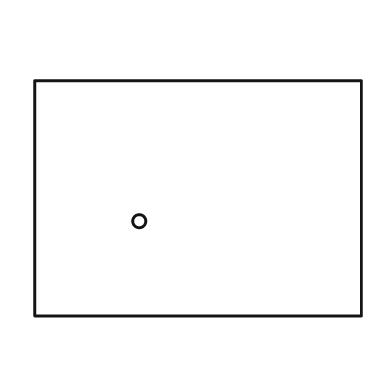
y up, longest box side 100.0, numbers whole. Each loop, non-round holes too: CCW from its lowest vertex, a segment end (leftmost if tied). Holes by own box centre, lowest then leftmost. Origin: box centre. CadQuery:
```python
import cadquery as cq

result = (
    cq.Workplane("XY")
    .moveTo(-50.0, -36.0)
    .lineTo(50.0, -36.0)
    .lineTo(50.0, 36.0)
    .lineTo(-50.0, 36.0)
    .close()
    .moveTo(-18.0, -7.0)
    .circle(2.0)
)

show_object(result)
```